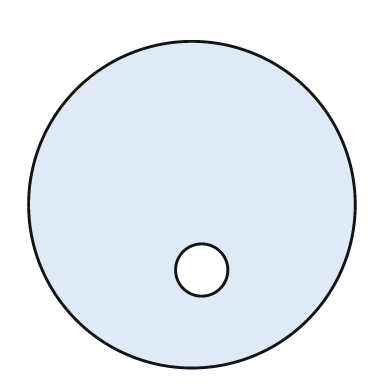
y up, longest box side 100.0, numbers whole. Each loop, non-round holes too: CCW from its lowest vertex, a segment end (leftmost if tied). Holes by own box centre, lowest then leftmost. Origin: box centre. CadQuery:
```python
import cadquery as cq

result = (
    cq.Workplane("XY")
    .moveTo(0.0, 0.0)
    .circle(50.0)
    .moveTo(3.0, -20.0)
    .circle(8.0)
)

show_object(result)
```